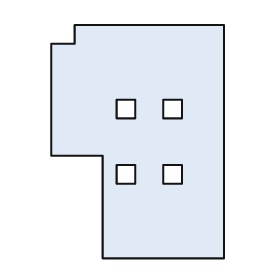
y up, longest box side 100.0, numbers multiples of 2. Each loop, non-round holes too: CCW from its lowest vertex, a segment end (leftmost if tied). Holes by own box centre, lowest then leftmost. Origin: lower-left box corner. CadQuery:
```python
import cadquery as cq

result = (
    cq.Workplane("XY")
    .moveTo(22.0, 0.0)
    .lineTo(74.0, 0.0)
    .lineTo(74.0, 100.0)
    .lineTo(10.0, 100.0)
    .lineTo(10.0, 92.0)
    .lineTo(0.0, 92.0)
    .lineTo(0.0, 44.0)
    .lineTo(22.0, 44.0)
    .close()
    .moveTo(28.0, 32.0)
    .lineTo(36.0, 32.0)
    .lineTo(36.0, 40.0)
    .lineTo(28.0, 40.0)
    .close()
    .moveTo(48.0, 32.0)
    .lineTo(56.0, 32.0)
    .lineTo(56.0, 40.0)
    .lineTo(48.0, 40.0)
    .close()
    .moveTo(28.0, 60.0)
    .lineTo(36.0, 60.0)
    .lineTo(36.0, 68.0)
    .lineTo(28.0, 68.0)
    .close()
    .moveTo(48.0, 60.0)
    .lineTo(56.0, 60.0)
    .lineTo(56.0, 68.0)
    .lineTo(48.0, 68.0)
    .close()
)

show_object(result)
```